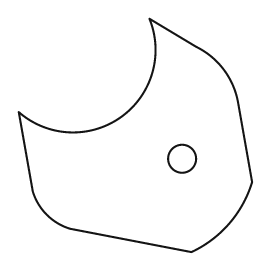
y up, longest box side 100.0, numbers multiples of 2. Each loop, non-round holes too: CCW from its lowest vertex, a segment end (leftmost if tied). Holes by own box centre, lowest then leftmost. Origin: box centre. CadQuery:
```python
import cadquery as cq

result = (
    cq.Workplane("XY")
    .moveTo(24.0, -50.0)
    .threePointArc((40.0, -38.0), (50.0, -20.0))
    .lineTo(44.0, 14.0)
    .threePointArc((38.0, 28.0), (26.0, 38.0))
    .lineTo(6.0, 50.0)
    .threePointArc((-6.0, 8.0), (-50.0, 10.0))
    .lineTo(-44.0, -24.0)
    .threePointArc((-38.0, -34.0), (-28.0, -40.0))
    .close()
    .moveTo(20.0, -10.0)
    .circle(6.0)
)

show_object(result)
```